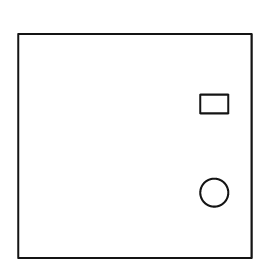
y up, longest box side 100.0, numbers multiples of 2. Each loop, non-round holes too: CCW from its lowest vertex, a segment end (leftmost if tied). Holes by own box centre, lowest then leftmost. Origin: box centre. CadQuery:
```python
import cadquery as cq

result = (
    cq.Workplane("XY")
    .moveTo(-50.0, -48.0)
    .lineTo(50.0, -48.0)
    .lineTo(50.0, 48.0)
    .lineTo(-50.0, 48.0)
    .close()
    .moveTo(34.0, -20.0)
    .circle(6.0)
    .moveTo(28.0, 14.0)
    .lineTo(40.0, 14.0)
    .lineTo(40.0, 22.0)
    .lineTo(28.0, 22.0)
    .close()
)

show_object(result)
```